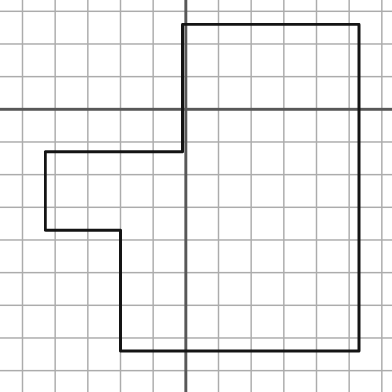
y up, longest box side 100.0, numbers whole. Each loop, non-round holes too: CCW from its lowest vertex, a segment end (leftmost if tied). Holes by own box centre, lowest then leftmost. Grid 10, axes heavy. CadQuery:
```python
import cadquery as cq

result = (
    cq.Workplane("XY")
    .moveTo(-20.0, -74.0)
    .lineTo(53.0, -74.0)
    .lineTo(53.0, 26.0)
    .lineTo(-1.0, 26.0)
    .lineTo(-1.0, -13.0)
    .lineTo(-43.0, -13.0)
    .lineTo(-43.0, -37.0)
    .lineTo(-20.0, -37.0)
    .close()
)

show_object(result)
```